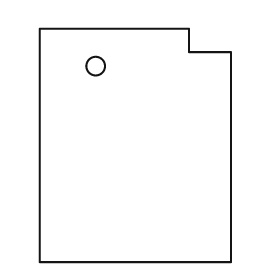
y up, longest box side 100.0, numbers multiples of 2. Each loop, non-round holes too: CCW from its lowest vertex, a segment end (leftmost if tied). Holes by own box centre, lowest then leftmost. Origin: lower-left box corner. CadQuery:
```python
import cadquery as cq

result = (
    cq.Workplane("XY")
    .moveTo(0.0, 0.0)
    .lineTo(82.0, 0.0)
    .lineTo(82.0, 90.0)
    .lineTo(64.0, 90.0)
    .lineTo(64.0, 100.0)
    .lineTo(0.0, 100.0)
    .close()
    .moveTo(24.0, 84.0)
    .circle(4.0)
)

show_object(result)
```